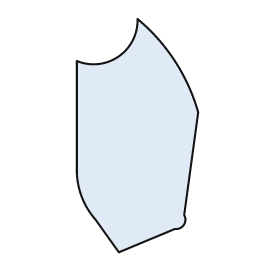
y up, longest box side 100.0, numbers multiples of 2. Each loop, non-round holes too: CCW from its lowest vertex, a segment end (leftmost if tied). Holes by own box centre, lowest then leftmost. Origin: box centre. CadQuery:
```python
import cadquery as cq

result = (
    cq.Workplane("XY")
    .moveTo(-8.0, -50.0)
    .lineTo(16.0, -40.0)
    .threePointArc((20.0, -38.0), (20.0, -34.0))
    .lineTo(26.0, 10.0)
    .threePointArc((16.0, 32.0), (0.0, 50.0))
    .threePointArc((-8.0, 34.0), (-26.0, 32.0))
    .lineTo(-26.0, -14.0)
    .threePointArc((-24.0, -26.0), (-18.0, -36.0))
    .close()
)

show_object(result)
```